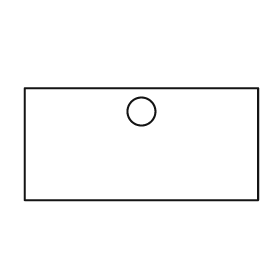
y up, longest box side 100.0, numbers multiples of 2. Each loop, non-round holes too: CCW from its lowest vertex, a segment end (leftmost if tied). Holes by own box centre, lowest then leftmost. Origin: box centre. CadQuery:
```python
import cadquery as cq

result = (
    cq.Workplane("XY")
    .moveTo(-50.0, -24.0)
    .lineTo(50.0, -24.0)
    .lineTo(50.0, 24.0)
    .lineTo(-50.0, 24.0)
    .close()
    .moveTo(0.0, 14.0)
    .circle(6.0)
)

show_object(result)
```